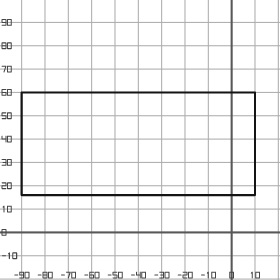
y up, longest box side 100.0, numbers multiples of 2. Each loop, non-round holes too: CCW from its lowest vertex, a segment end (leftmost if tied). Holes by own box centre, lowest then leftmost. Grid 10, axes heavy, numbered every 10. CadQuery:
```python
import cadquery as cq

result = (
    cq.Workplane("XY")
    .moveTo(-90.0, 16.0)
    .lineTo(10.0, 16.0)
    .lineTo(10.0, 60.0)
    .lineTo(-90.0, 60.0)
    .close()
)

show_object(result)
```